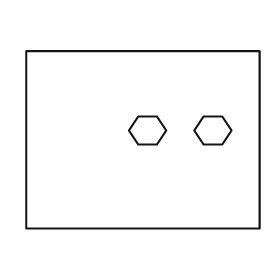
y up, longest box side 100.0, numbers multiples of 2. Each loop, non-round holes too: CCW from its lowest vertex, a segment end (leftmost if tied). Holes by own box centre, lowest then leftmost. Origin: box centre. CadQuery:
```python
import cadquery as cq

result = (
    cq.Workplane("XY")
    .moveTo(-50.0, -38.0)
    .lineTo(50.0, -38.0)
    .lineTo(50.0, 38.0)
    .lineTo(-50.0, 38.0)
    .close()
    .moveTo(-2.0, -2.0)
    .lineTo(6.0, -2.0)
    .lineTo(10.0, 4.0)
    .lineTo(6.0, 10.0)
    .lineTo(-2.0, 10.0)
    .lineTo(-6.0, 4.0)
    .close()
    .moveTo(26.0, -2.0)
    .lineTo(34.0, -2.0)
    .lineTo(38.0, 4.0)
    .lineTo(34.0, 10.0)
    .lineTo(26.0, 10.0)
    .lineTo(22.0, 4.0)
    .close()
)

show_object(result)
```